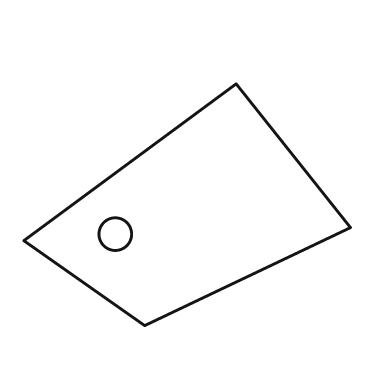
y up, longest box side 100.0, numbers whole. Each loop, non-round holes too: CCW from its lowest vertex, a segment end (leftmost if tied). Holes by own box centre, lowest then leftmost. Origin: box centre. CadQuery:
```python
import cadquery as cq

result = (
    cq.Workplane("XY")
    .moveTo(-13.0, -37.0)
    .lineTo(50.0, -7.0)
    .lineTo(15.0, 37.0)
    .lineTo(-50.0, -11.0)
    .close()
    .moveTo(-22.0, -9.0)
    .circle(5.0)
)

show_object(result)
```